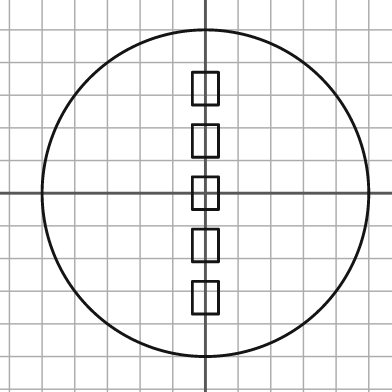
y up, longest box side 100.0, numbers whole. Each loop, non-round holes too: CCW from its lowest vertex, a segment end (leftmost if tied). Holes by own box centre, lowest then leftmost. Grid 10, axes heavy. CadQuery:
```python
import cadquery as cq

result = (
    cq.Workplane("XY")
    .moveTo(0.0, 0.0)
    .circle(50.0)
    .moveTo(-4.0, -37.0)
    .lineTo(4.0, -37.0)
    .lineTo(4.0, -27.0)
    .lineTo(-4.0, -27.0)
    .close()
    .moveTo(-4.0, -21.0)
    .lineTo(4.0, -21.0)
    .lineTo(4.0, -11.0)
    .lineTo(-4.0, -11.0)
    .close()
    .moveTo(-4.0, -5.0)
    .lineTo(4.0, -5.0)
    .lineTo(4.0, 5.0)
    .lineTo(-4.0, 5.0)
    .close()
    .moveTo(-4.0, 11.0)
    .lineTo(4.0, 11.0)
    .lineTo(4.0, 21.0)
    .lineTo(-4.0, 21.0)
    .close()
    .moveTo(-4.0, 27.0)
    .lineTo(4.0, 27.0)
    .lineTo(4.0, 37.0)
    .lineTo(-4.0, 37.0)
    .close()
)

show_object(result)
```